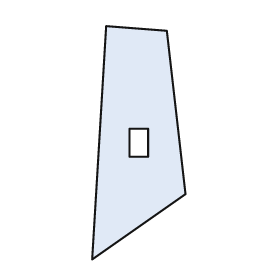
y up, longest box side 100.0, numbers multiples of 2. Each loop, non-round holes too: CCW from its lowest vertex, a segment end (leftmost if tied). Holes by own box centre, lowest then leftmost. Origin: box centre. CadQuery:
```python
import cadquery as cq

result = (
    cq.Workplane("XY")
    .moveTo(-20.0, -50.0)
    .lineTo(20.0, -22.0)
    .lineTo(12.0, 48.0)
    .lineTo(-14.0, 50.0)
    .close()
    .moveTo(-4.0, -6.0)
    .lineTo(4.0, -6.0)
    .lineTo(4.0, 6.0)
    .lineTo(-4.0, 6.0)
    .close()
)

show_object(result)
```